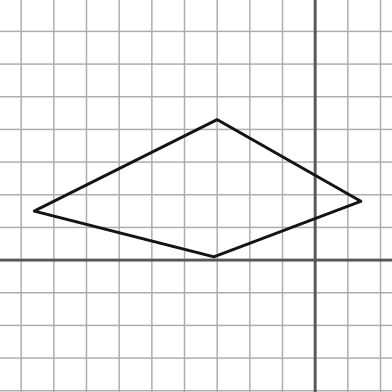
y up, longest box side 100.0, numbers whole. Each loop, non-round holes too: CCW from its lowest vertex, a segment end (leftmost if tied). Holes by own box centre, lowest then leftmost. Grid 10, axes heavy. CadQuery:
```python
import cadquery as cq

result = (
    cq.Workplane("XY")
    .moveTo(-31.0, 1.0)
    .lineTo(14.0, 18.0)
    .lineTo(-30.0, 43.0)
    .lineTo(-86.0, 15.0)
    .close()
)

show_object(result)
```